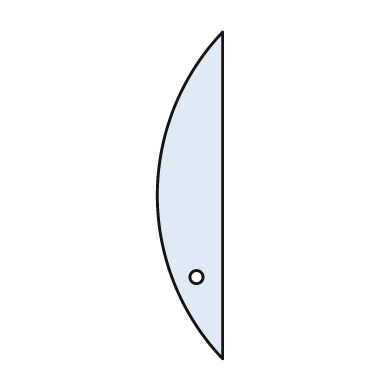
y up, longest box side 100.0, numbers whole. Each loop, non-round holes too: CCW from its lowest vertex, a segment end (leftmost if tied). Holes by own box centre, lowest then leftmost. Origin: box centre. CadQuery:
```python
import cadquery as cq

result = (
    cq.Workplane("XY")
    .moveTo(10.0, -50.0)
    .lineTo(10.0, 50.0)
    .threePointArc((-10.0, 0.0), (10.0, -50.0))
    .close()
    .moveTo(2.0, -25.0)
    .circle(2.0)
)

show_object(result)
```